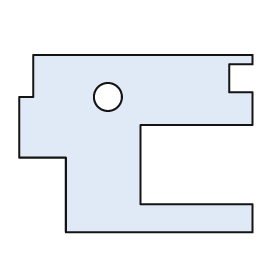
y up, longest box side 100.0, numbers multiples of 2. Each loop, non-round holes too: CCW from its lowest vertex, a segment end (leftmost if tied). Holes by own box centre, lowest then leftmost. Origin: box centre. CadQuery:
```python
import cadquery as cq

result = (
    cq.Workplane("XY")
    .moveTo(-30.0, -38.0)
    .lineTo(50.0, -38.0)
    .lineTo(50.0, -26.0)
    .lineTo(2.0, -26.0)
    .lineTo(2.0, 8.0)
    .lineTo(50.0, 8.0)
    .lineTo(50.0, 22.0)
    .lineTo(40.0, 22.0)
    .lineTo(40.0, 34.0)
    .lineTo(50.0, 34.0)
    .lineTo(50.0, 38.0)
    .lineTo(-44.0, 38.0)
    .lineTo(-44.0, 20.0)
    .lineTo(-50.0, 20.0)
    .lineTo(-50.0, -6.0)
    .lineTo(-30.0, -6.0)
    .close()
    .moveTo(-12.0, 20.0)
    .circle(6.0)
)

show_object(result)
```